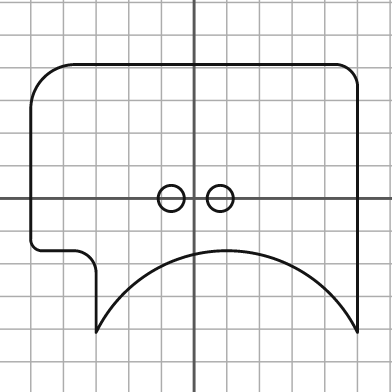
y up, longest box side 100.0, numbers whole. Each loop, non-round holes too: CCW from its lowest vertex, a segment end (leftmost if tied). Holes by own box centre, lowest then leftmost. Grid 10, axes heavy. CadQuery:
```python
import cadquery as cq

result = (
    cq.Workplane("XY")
    .moveTo(-30.0, -41.0)
    .threePointArc((10.0, -16.0), (50.0, -41.0))
    .lineTo(50.0, 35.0)
    .threePointArc((48.0, 39.0), (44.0, 41.0))
    .lineTo(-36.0, 41.0)
    .threePointArc((-46.0, 37.0), (-50.0, 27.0))
    .lineTo(-50.0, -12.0)
    .threePointArc((-49.0, -15.0), (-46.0, -16.0))
    .lineTo(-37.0, -16.0)
    .threePointArc((-32.0, -18.0), (-30.0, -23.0))
    .close()
    .moveTo(-7.0, 0.0)
    .circle(4.0)
    .moveTo(8.0, 0.0)
    .circle(4.0)
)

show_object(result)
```